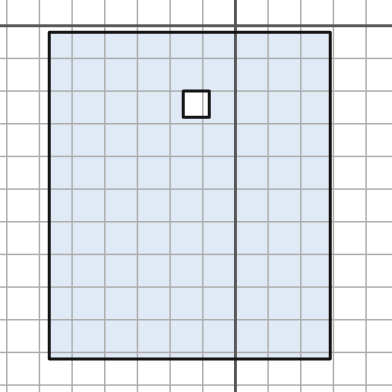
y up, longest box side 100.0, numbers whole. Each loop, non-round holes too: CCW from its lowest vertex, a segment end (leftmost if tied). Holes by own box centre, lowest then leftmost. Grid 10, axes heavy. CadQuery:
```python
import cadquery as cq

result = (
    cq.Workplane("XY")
    .moveTo(-57.0, -102.0)
    .lineTo(29.0, -102.0)
    .lineTo(29.0, -2.0)
    .lineTo(-57.0, -2.0)
    .close()
    .moveTo(-16.0, -28.0)
    .lineTo(-8.0, -28.0)
    .lineTo(-8.0, -20.0)
    .lineTo(-16.0, -20.0)
    .close()
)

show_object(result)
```